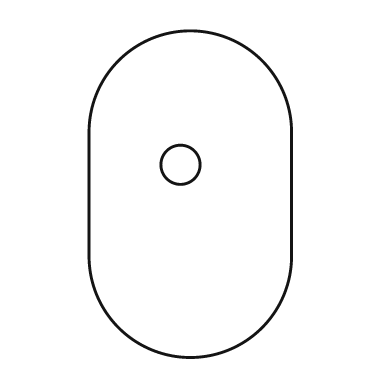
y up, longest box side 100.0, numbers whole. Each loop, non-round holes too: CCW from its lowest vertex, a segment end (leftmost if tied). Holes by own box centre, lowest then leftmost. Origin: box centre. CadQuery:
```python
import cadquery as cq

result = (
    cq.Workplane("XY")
    .moveTo(-31.0, -19.0)
    .threePointArc((0.0, -50.0), (31.0, -19.0))
    .lineTo(31.0, 19.0)
    .threePointArc((0.0, 50.0), (-31.0, 19.0))
    .close()
    .moveTo(-3.0, 9.0)
    .circle(6.0)
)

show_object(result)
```